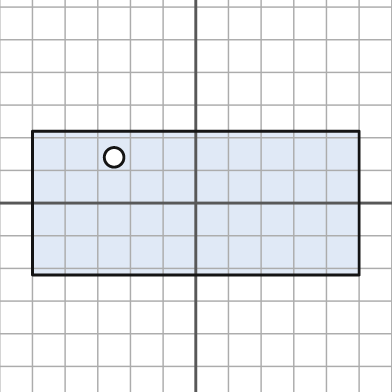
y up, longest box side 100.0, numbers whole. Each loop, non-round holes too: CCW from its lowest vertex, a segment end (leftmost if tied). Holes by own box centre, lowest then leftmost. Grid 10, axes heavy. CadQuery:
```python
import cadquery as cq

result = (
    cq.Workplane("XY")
    .moveTo(-50.0, -22.0)
    .lineTo(50.0, -22.0)
    .lineTo(50.0, 22.0)
    .lineTo(-50.0, 22.0)
    .close()
    .moveTo(-25.0, 14.0)
    .circle(3.0)
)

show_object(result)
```